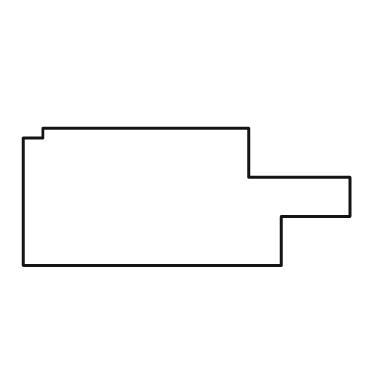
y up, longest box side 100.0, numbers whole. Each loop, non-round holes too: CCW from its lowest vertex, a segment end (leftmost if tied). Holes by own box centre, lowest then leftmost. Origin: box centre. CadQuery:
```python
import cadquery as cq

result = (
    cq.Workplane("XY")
    .moveTo(-50.0, -21.0)
    .lineTo(29.0, -21.0)
    .lineTo(29.0, -6.0)
    .lineTo(50.0, -6.0)
    .lineTo(50.0, 6.0)
    .lineTo(19.0, 6.0)
    .lineTo(19.0, 21.0)
    .lineTo(-44.0, 21.0)
    .lineTo(-44.0, 18.0)
    .lineTo(-50.0, 18.0)
    .close()
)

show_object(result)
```